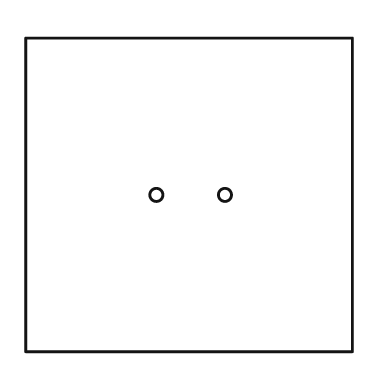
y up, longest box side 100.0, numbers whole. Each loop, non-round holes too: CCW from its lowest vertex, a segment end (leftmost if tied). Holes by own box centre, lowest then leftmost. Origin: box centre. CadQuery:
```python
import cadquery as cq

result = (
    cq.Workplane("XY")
    .moveTo(-50.0, -48.0)
    .lineTo(50.0, -48.0)
    .lineTo(50.0, 48.0)
    .lineTo(-50.0, 48.0)
    .close()
    .moveTo(-10.0, 0.0)
    .circle(2.0)
    .moveTo(11.0, 0.0)
    .circle(2.0)
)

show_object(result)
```